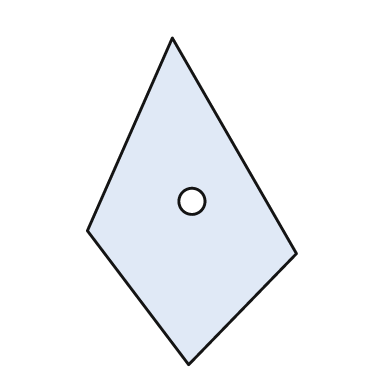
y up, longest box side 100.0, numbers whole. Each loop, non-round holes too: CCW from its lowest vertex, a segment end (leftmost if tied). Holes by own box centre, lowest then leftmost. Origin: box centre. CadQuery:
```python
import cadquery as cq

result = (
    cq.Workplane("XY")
    .moveTo(-1.0, -50.0)
    .lineTo(32.0, -16.0)
    .lineTo(-6.0, 50.0)
    .lineTo(-32.0, -9.0)
    .close()
    .moveTo(0.0, 0.0)
    .circle(4.0)
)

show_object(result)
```